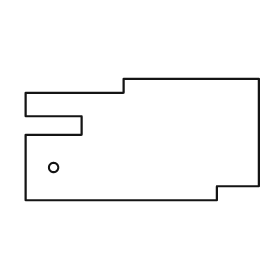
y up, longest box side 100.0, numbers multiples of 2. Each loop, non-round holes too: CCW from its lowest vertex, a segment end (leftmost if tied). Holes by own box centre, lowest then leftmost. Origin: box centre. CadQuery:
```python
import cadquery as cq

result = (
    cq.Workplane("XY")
    .moveTo(-50.0, -26.0)
    .lineTo(32.0, -26.0)
    .lineTo(32.0, -20.0)
    .lineTo(50.0, -20.0)
    .lineTo(50.0, 26.0)
    .lineTo(-8.0, 26.0)
    .lineTo(-8.0, 20.0)
    .lineTo(-50.0, 20.0)
    .lineTo(-50.0, 10.0)
    .lineTo(-26.0, 10.0)
    .lineTo(-26.0, 2.0)
    .lineTo(-50.0, 2.0)
    .close()
    .moveTo(-38.0, -12.0)
    .circle(2.0)
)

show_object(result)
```